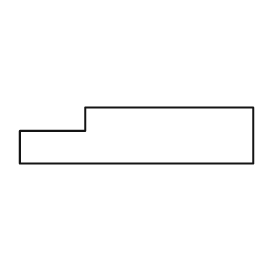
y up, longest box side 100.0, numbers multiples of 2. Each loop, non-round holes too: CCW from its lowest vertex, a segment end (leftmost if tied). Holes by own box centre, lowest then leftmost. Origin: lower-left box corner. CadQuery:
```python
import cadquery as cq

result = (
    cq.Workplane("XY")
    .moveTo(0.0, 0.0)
    .lineTo(100.0, 0.0)
    .lineTo(100.0, 24.0)
    .lineTo(28.0, 24.0)
    .lineTo(28.0, 14.0)
    .lineTo(0.0, 14.0)
    .close()
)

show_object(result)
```